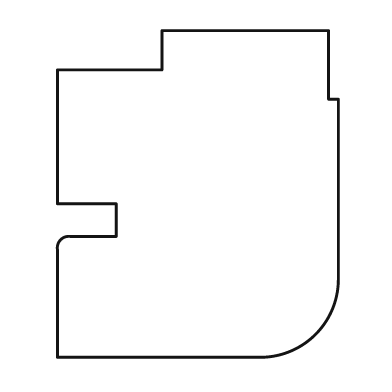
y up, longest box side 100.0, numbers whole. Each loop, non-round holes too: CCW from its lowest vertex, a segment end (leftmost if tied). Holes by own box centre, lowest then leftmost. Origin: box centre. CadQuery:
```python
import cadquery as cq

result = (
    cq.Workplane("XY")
    .moveTo(-43.0, -50.0)
    .lineTo(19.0, -50.0)
    .threePointArc((36.0, -43.0), (43.0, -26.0))
    .lineTo(43.0, 29.0)
    .lineTo(40.0, 29.0)
    .lineTo(40.0, 50.0)
    .lineTo(-11.0, 50.0)
    .lineTo(-11.0, 38.0)
    .lineTo(-43.0, 38.0)
    .lineTo(-43.0, -3.0)
    .lineTo(-25.0, -3.0)
    .lineTo(-25.0, -13.0)
    .lineTo(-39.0, -13.0)
    .threePointArc((-42.0, -14.0), (-43.0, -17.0))
    .close()
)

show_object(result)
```